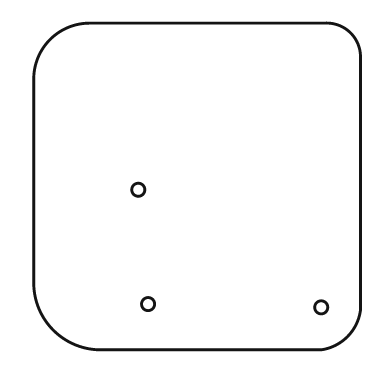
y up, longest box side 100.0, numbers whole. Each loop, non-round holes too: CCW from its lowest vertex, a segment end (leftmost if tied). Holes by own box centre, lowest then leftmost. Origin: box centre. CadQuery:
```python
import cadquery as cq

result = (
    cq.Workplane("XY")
    .moveTo(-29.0, -50.0)
    .lineTo(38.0, -50.0)
    .threePointArc((46.0, -46.0), (50.0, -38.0))
    .lineTo(50.0, 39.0)
    .threePointArc((47.0, 47.0), (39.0, 50.0))
    .lineTo(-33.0, 50.0)
    .threePointArc((-45.0, 45.0), (-50.0, 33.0))
    .lineTo(-50.0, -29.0)
    .threePointArc((-44.0, -44.0), (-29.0, -50.0))
    .close()
    .moveTo(38.0, -37.0)
    .circle(2.0)
    .moveTo(-15.0, -36.0)
    .circle(2.0)
    .moveTo(-18.0, -1.0)
    .circle(2.0)
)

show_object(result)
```